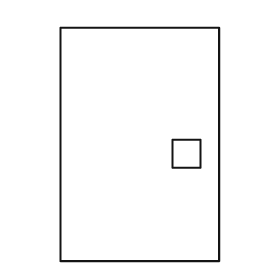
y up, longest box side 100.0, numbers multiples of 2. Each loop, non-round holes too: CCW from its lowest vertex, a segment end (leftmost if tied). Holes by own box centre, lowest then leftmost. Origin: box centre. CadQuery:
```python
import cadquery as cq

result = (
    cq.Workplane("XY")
    .moveTo(-34.0, -50.0)
    .lineTo(34.0, -50.0)
    .lineTo(34.0, 50.0)
    .lineTo(-34.0, 50.0)
    .close()
    .moveTo(14.0, -10.0)
    .lineTo(26.0, -10.0)
    .lineTo(26.0, 2.0)
    .lineTo(14.0, 2.0)
    .close()
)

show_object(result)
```